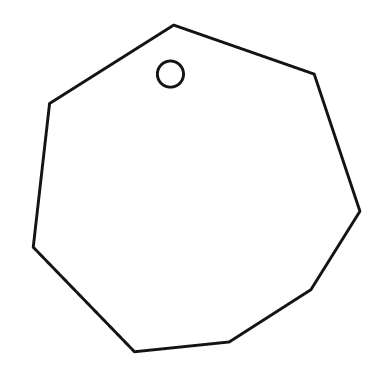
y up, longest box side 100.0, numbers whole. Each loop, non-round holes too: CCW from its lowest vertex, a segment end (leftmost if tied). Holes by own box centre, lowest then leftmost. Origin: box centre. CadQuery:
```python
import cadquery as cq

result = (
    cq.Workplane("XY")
    .moveTo(-19.0, -50.0)
    .lineTo(10.0, -47.0)
    .lineTo(35.0, -31.0)
    .lineTo(50.0, -7.0)
    .lineTo(36.0, 35.0)
    .lineTo(-7.0, 50.0)
    .lineTo(-45.0, 26.0)
    .lineTo(-50.0, -18.0)
    .close()
    .moveTo(-8.0, 35.0)
    .circle(4.0)
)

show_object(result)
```